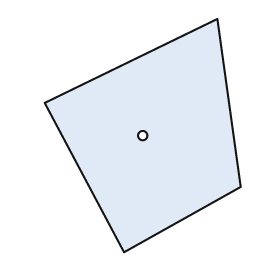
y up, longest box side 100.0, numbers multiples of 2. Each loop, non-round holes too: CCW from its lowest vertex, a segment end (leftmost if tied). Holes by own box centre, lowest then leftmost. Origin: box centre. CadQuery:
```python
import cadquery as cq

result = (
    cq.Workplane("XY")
    .moveTo(-8.0, -50.0)
    .lineTo(42.0, -22.0)
    .lineTo(32.0, 50.0)
    .lineTo(-42.0, 14.0)
    .close()
    .moveTo(0.0, 0.0)
    .circle(2.0)
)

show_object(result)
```